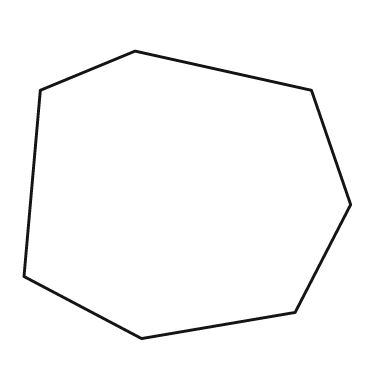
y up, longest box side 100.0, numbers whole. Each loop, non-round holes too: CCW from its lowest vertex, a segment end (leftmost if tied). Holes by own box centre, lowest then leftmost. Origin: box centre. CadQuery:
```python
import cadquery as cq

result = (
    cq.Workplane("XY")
    .moveTo(-14.0, -44.0)
    .lineTo(33.0, -36.0)
    .lineTo(50.0, -3.0)
    .lineTo(38.0, 32.0)
    .lineTo(-16.0, 44.0)
    .lineTo(-45.0, 32.0)
    .lineTo(-50.0, -25.0)
    .close()
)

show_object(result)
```